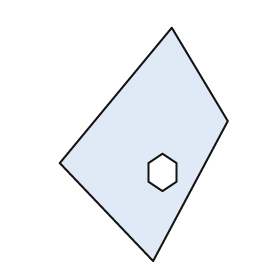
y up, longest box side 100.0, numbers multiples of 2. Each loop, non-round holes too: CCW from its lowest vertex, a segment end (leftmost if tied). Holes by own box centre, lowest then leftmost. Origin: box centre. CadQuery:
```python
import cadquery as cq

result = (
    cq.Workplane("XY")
    .moveTo(4.0, -50.0)
    .lineTo(36.0, 10.0)
    .lineTo(12.0, 50.0)
    .lineTo(-36.0, -8.0)
    .close()
    .moveTo(8.0, -20.0)
    .lineTo(14.0, -16.0)
    .lineTo(14.0, -8.0)
    .lineTo(8.0, -4.0)
    .lineTo(2.0, -8.0)
    .lineTo(2.0, -16.0)
    .close()
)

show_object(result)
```